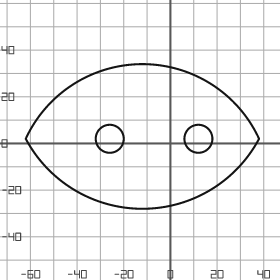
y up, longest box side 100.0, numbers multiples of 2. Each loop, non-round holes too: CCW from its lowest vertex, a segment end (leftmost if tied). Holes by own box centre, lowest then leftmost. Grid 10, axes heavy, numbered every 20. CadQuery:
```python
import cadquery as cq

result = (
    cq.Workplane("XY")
    .moveTo(-62.0, 2.0)
    .threePointArc((-12.0, -28.0), (38.0, 2.0))
    .threePointArc((-12.0, 34.0), (-62.0, 2.0))
    .close()
    .moveTo(-26.0, 2.0)
    .circle(6.0)
    .moveTo(12.0, 2.0)
    .circle(6.0)
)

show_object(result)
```